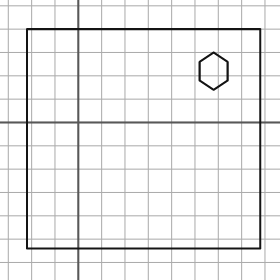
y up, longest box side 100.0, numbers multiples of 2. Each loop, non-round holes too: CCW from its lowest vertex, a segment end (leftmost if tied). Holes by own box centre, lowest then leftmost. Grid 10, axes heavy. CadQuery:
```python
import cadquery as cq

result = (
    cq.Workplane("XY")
    .moveTo(-22.0, -54.0)
    .lineTo(78.0, -54.0)
    .lineTo(78.0, 40.0)
    .lineTo(-22.0, 40.0)
    .close()
    .moveTo(58.0, 14.0)
    .lineTo(64.0, 18.0)
    .lineTo(64.0, 26.0)
    .lineTo(58.0, 30.0)
    .lineTo(52.0, 26.0)
    .lineTo(52.0, 18.0)
    .close()
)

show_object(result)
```